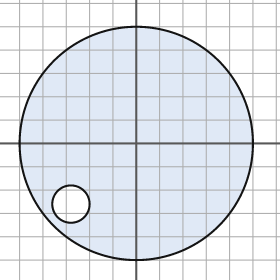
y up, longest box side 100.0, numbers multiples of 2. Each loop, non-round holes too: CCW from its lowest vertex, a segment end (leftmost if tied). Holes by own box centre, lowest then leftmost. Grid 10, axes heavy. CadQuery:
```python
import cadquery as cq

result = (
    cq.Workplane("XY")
    .moveTo(0.0, 0.0)
    .circle(50.0)
    .moveTo(-28.0, -26.0)
    .circle(8.0)
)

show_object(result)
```